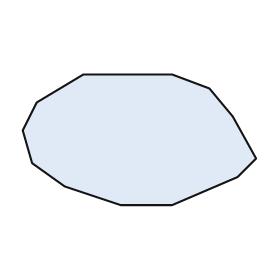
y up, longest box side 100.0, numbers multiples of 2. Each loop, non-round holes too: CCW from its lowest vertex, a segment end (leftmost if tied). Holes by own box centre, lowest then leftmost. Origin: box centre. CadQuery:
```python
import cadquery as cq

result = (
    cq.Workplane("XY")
    .moveTo(-8.0, -28.0)
    .lineTo(14.0, -28.0)
    .lineTo(42.0, -16.0)
    .lineTo(50.0, -8.0)
    .lineTo(40.0, 10.0)
    .lineTo(30.0, 22.0)
    .lineTo(14.0, 28.0)
    .lineTo(-24.0, 28.0)
    .lineTo(-44.0, 16.0)
    .lineTo(-50.0, 4.0)
    .lineTo(-46.0, -10.0)
    .lineTo(-32.0, -20.0)
    .close()
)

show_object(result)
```